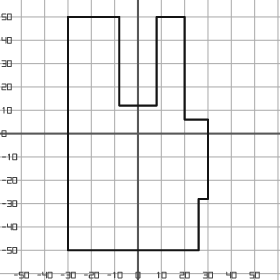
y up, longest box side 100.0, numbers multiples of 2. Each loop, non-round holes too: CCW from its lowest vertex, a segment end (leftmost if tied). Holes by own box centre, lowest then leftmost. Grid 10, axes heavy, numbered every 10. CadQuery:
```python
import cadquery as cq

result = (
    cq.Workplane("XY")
    .moveTo(-30.0, -50.0)
    .lineTo(26.0, -50.0)
    .lineTo(26.0, -28.0)
    .lineTo(30.0, -28.0)
    .lineTo(30.0, 6.0)
    .lineTo(20.0, 6.0)
    .lineTo(20.0, 50.0)
    .lineTo(8.0, 50.0)
    .lineTo(8.0, 12.0)
    .lineTo(-8.0, 12.0)
    .lineTo(-8.0, 50.0)
    .lineTo(-30.0, 50.0)
    .close()
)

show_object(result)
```